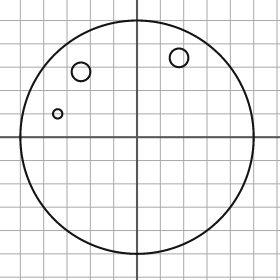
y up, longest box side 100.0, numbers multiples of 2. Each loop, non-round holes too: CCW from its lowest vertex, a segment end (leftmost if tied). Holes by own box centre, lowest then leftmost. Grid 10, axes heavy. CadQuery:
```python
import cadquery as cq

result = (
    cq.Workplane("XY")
    .moveTo(0.0, 0.0)
    .circle(50.0)
    .moveTo(-34.0, 10.0)
    .circle(2.0)
    .moveTo(-24.0, 28.0)
    .circle(4.0)
    .moveTo(18.0, 34.0)
    .circle(4.0)
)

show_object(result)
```